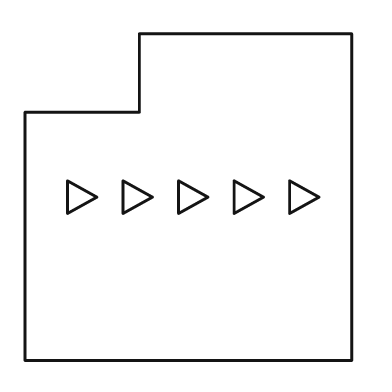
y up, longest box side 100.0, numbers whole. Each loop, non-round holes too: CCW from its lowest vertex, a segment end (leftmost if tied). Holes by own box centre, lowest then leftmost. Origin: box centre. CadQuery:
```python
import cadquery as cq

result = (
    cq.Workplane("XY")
    .moveTo(-50.0, -50.0)
    .lineTo(50.0, -50.0)
    .lineTo(50.0, 50.0)
    .lineTo(-15.0, 50.0)
    .lineTo(-15.0, 26.0)
    .lineTo(-50.0, 26.0)
    .close()
    .moveTo(-37.0, -5.0)
    .lineTo(-28.0, 0.0)
    .lineTo(-37.0, 5.0)
    .close()
    .moveTo(-20.0, -5.0)
    .lineTo(-11.0, 0.0)
    .lineTo(-20.0, 5.0)
    .close()
    .moveTo(-3.0, -5.0)
    .lineTo(6.0, 0.0)
    .lineTo(-3.0, 5.0)
    .close()
    .moveTo(14.0, -5.0)
    .lineTo(23.0, 0.0)
    .lineTo(14.0, 5.0)
    .close()
    .moveTo(31.0, -5.0)
    .lineTo(40.0, 0.0)
    .lineTo(31.0, 5.0)
    .close()
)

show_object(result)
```